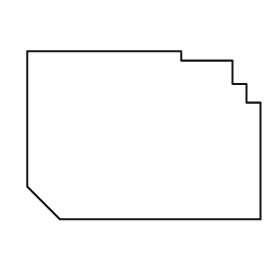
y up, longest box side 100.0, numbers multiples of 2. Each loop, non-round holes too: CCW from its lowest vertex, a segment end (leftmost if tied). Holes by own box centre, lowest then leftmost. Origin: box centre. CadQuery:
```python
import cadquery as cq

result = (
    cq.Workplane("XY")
    .moveTo(-36.0, -36.0)
    .lineTo(50.0, -36.0)
    .lineTo(50.0, 14.0)
    .lineTo(44.0, 14.0)
    .lineTo(44.0, 22.0)
    .lineTo(38.0, 22.0)
    .lineTo(38.0, 32.0)
    .lineTo(16.0, 32.0)
    .lineTo(16.0, 36.0)
    .lineTo(-50.0, 36.0)
    .lineTo(-50.0, -22.0)
    .close()
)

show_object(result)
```